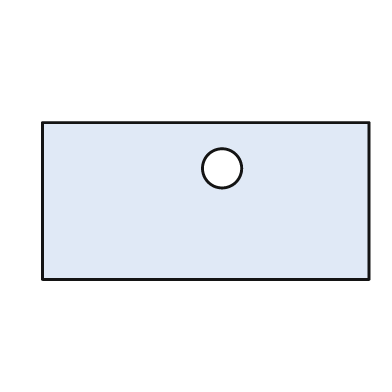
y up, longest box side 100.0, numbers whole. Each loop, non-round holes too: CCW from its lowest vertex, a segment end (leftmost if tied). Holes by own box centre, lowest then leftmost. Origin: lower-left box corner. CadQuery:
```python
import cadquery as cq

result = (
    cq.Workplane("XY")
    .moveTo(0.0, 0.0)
    .lineTo(100.0, 0.0)
    .lineTo(100.0, 48.0)
    .lineTo(0.0, 48.0)
    .close()
    .moveTo(55.0, 34.0)
    .circle(6.0)
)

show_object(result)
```